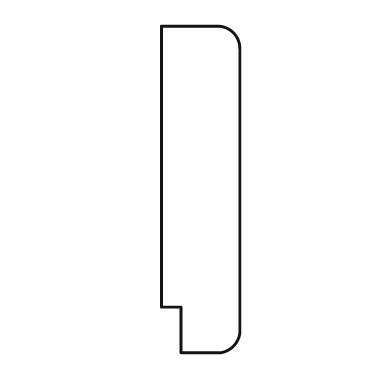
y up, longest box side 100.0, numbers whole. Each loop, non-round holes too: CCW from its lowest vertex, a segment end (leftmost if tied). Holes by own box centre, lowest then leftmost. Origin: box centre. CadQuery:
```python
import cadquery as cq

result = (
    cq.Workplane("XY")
    .moveTo(-6.0, -50.0)
    .lineTo(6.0, -50.0)
    .threePointArc((10.0, -48.0), (12.0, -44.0))
    .lineTo(12.0, 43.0)
    .threePointArc((10.0, 48.0), (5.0, 50.0))
    .lineTo(-12.0, 50.0)
    .lineTo(-12.0, -36.0)
    .lineTo(-6.0, -36.0)
    .close()
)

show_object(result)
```